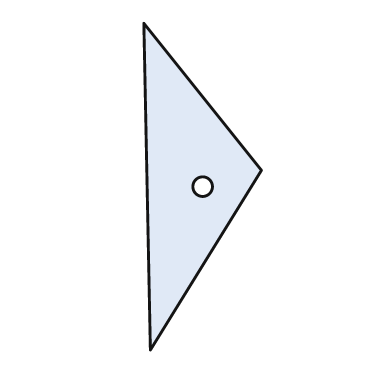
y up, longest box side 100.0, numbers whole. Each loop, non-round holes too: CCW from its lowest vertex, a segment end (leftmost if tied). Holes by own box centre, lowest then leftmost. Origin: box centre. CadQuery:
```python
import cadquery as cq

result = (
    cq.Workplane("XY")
    .moveTo(-16.0, -50.0)
    .lineTo(18.0, 5.0)
    .lineTo(-18.0, 50.0)
    .close()
    .moveTo(0.0, 0.0)
    .circle(3.0)
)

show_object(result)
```